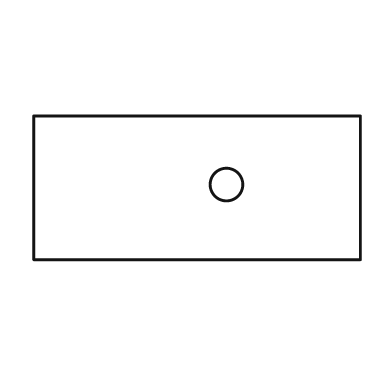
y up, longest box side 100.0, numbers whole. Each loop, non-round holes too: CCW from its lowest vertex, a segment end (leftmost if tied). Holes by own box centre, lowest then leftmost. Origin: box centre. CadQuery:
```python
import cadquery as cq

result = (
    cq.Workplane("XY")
    .moveTo(-50.0, -22.0)
    .lineTo(50.0, -22.0)
    .lineTo(50.0, 22.0)
    .lineTo(-50.0, 22.0)
    .close()
    .moveTo(9.0, 1.0)
    .circle(5.0)
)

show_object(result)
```